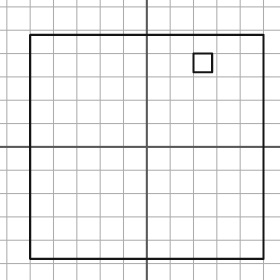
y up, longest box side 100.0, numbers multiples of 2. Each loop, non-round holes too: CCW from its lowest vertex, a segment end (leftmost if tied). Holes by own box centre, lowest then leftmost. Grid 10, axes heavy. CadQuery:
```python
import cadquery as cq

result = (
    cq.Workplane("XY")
    .moveTo(-50.0, -48.0)
    .lineTo(50.0, -48.0)
    .lineTo(50.0, 48.0)
    .lineTo(-50.0, 48.0)
    .close()
    .moveTo(20.0, 32.0)
    .lineTo(28.0, 32.0)
    .lineTo(28.0, 40.0)
    .lineTo(20.0, 40.0)
    .close()
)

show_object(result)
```